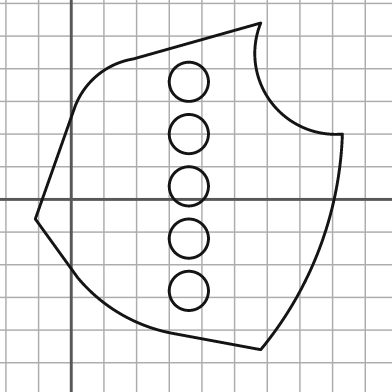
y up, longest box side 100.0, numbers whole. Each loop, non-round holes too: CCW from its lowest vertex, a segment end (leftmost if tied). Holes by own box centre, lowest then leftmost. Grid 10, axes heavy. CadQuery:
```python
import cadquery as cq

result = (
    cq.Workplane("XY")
    .moveTo(58.0, -46.0)
    .threePointArc((76.0, -15.0), (83.0, 20.0))
    .threePointArc((61.0, 30.0), (58.0, 54.0))
    .lineTo(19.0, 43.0)
    .threePointArc((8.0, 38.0), (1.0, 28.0))
    .lineTo(-11.0, -6.0)
    .lineTo(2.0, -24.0)
    .threePointArc((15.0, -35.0), (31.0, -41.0))
    .close()
    .moveTo(36.0, -28.0)
    .circle(6.0)
    .moveTo(36.0, -12.0)
    .circle(6.0)
    .moveTo(36.0, 4.0)
    .circle(6.0)
    .moveTo(36.0, 20.0)
    .circle(6.0)
    .moveTo(36.0, 36.0)
    .circle(6.0)
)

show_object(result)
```